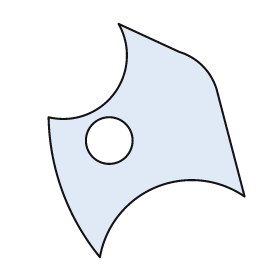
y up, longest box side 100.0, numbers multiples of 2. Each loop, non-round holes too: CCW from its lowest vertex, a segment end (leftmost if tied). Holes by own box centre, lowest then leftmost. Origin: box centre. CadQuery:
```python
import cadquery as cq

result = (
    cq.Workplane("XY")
    .moveTo(-20.0, -50.0)
    .threePointArc((4.0, -20.0), (42.0, -24.0))
    .lineTo(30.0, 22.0)
    .threePointArc((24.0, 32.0), (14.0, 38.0))
    .lineTo(-12.0, 50.0)
    .threePointArc((-14.0, 20.0), (-42.0, 10.0))
    .threePointArc((-36.0, -22.0), (-20.0, -50.0))
    .close()
    .moveTo(-16.0, 0.0)
    .circle(10.0)
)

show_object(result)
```